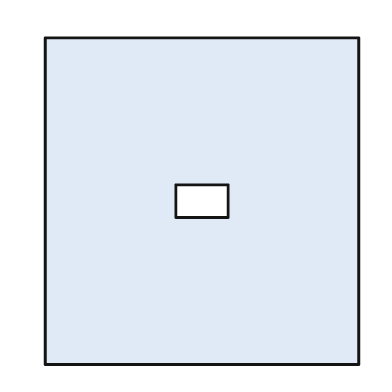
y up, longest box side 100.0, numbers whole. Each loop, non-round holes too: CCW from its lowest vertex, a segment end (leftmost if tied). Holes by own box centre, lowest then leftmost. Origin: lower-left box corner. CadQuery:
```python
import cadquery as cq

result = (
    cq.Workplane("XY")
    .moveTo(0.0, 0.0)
    .lineTo(96.0, 0.0)
    .lineTo(96.0, 100.0)
    .lineTo(0.0, 100.0)
    .close()
    .moveTo(40.0, 45.0)
    .lineTo(56.0, 45.0)
    .lineTo(56.0, 55.0)
    .lineTo(40.0, 55.0)
    .close()
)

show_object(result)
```